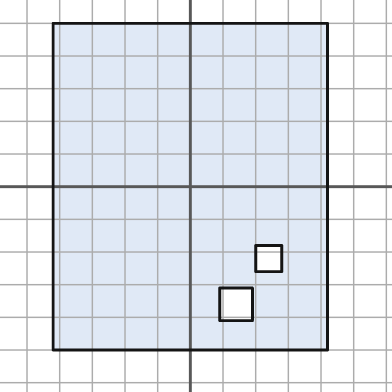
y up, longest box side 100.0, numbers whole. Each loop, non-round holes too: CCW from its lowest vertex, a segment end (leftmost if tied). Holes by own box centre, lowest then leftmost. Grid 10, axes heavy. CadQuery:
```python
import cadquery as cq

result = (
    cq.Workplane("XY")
    .moveTo(-42.0, -50.0)
    .lineTo(42.0, -50.0)
    .lineTo(42.0, 50.0)
    .lineTo(-42.0, 50.0)
    .close()
    .moveTo(9.0, -41.0)
    .lineTo(19.0, -41.0)
    .lineTo(19.0, -31.0)
    .lineTo(9.0, -31.0)
    .close()
    .moveTo(20.0, -26.0)
    .lineTo(28.0, -26.0)
    .lineTo(28.0, -18.0)
    .lineTo(20.0, -18.0)
    .close()
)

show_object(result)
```